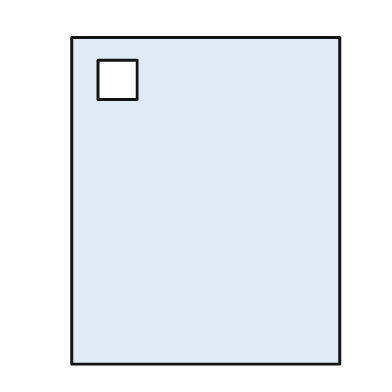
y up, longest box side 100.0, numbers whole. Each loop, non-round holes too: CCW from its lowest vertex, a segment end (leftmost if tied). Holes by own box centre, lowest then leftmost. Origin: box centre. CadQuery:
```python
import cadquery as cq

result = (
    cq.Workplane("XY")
    .moveTo(-41.0, -50.0)
    .lineTo(41.0, -50.0)
    .lineTo(41.0, 50.0)
    .lineTo(-41.0, 50.0)
    .close()
    .moveTo(-33.0, 31.0)
    .lineTo(-21.0, 31.0)
    .lineTo(-21.0, 43.0)
    .lineTo(-33.0, 43.0)
    .close()
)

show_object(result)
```